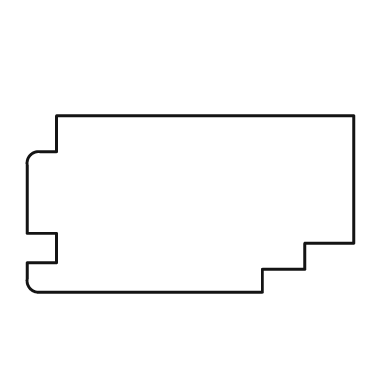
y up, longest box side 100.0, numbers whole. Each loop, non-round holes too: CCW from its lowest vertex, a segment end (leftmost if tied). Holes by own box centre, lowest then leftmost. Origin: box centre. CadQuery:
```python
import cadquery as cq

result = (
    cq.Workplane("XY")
    .moveTo(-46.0, -27.0)
    .lineTo(22.0, -27.0)
    .lineTo(22.0, -20.0)
    .lineTo(35.0, -20.0)
    .lineTo(35.0, -12.0)
    .lineTo(50.0, -12.0)
    .lineTo(50.0, 27.0)
    .lineTo(-41.0, 27.0)
    .lineTo(-41.0, 16.0)
    .lineTo(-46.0, 16.0)
    .threePointArc((-49.0, 15.0), (-50.0, 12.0))
    .lineTo(-50.0, -9.0)
    .lineTo(-41.0, -9.0)
    .lineTo(-41.0, -18.0)
    .lineTo(-50.0, -18.0)
    .lineTo(-50.0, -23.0)
    .threePointArc((-49.0, -26.0), (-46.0, -27.0))
    .close()
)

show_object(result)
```